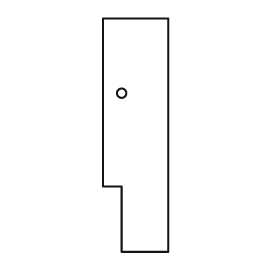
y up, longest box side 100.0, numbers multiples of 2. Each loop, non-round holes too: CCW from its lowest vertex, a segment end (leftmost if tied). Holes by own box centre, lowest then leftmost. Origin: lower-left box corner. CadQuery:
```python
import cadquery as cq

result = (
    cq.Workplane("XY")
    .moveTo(8.0, 0.0)
    .lineTo(28.0, 0.0)
    .lineTo(28.0, 100.0)
    .lineTo(0.0, 100.0)
    .lineTo(0.0, 28.0)
    .lineTo(8.0, 28.0)
    .close()
    .moveTo(8.0, 68.0)
    .circle(2.0)
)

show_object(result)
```